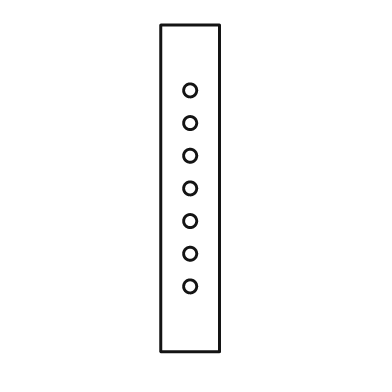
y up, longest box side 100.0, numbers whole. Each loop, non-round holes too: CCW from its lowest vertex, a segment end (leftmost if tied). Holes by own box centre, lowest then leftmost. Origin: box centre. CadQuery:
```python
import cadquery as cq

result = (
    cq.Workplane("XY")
    .moveTo(-9.0, -50.0)
    .lineTo(9.0, -50.0)
    .lineTo(9.0, 50.0)
    .lineTo(-9.0, 50.0)
    .close()
    .moveTo(0.0, -30.0)
    .circle(2.0)
    .moveTo(0.0, -20.0)
    .circle(2.0)
    .moveTo(0.0, -10.0)
    .circle(2.0)
    .moveTo(0.0, 0.0)
    .circle(2.0)
    .moveTo(0.0, 10.0)
    .circle(2.0)
    .moveTo(0.0, 20.0)
    .circle(2.0)
    .moveTo(0.0, 30.0)
    .circle(2.0)
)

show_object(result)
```